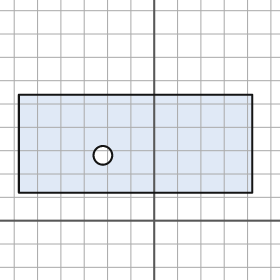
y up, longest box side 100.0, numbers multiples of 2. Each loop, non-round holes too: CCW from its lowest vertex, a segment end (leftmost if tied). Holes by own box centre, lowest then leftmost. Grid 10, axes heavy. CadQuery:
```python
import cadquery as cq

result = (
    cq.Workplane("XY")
    .moveTo(-58.0, 12.0)
    .lineTo(42.0, 12.0)
    .lineTo(42.0, 54.0)
    .lineTo(-58.0, 54.0)
    .close()
    .moveTo(-22.0, 28.0)
    .circle(4.0)
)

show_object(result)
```